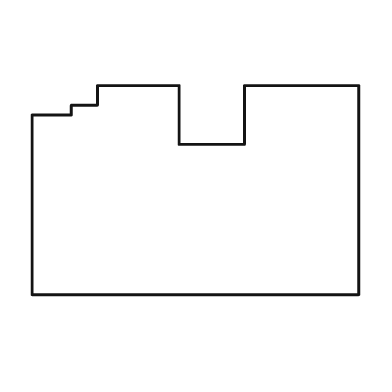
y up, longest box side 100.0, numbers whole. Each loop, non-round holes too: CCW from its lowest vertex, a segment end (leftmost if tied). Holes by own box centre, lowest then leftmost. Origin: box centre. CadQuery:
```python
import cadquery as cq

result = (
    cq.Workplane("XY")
    .moveTo(-50.0, -32.0)
    .lineTo(50.0, -32.0)
    .lineTo(50.0, 32.0)
    .lineTo(15.0, 32.0)
    .lineTo(15.0, 14.0)
    .lineTo(-5.0, 14.0)
    .lineTo(-5.0, 32.0)
    .lineTo(-30.0, 32.0)
    .lineTo(-30.0, 26.0)
    .lineTo(-38.0, 26.0)
    .lineTo(-38.0, 23.0)
    .lineTo(-50.0, 23.0)
    .close()
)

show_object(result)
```